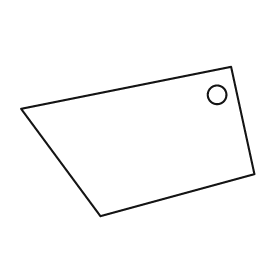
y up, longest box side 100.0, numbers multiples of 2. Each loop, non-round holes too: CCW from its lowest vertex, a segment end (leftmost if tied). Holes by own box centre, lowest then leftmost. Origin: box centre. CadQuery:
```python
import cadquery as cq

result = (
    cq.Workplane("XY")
    .moveTo(-16.0, -32.0)
    .lineTo(50.0, -14.0)
    .lineTo(40.0, 32.0)
    .lineTo(-50.0, 14.0)
    .close()
    .moveTo(34.0, 20.0)
    .circle(4.0)
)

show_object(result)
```